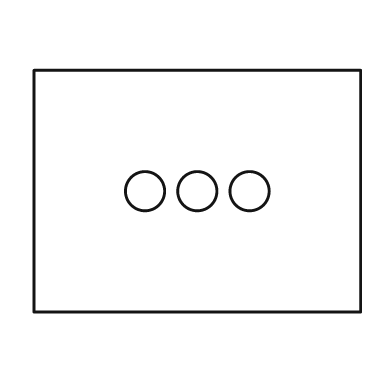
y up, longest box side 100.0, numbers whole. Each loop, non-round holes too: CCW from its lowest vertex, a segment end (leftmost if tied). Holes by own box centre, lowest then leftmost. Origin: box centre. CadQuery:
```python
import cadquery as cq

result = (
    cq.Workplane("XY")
    .moveTo(-50.0, -37.0)
    .lineTo(50.0, -37.0)
    .lineTo(50.0, 37.0)
    .lineTo(-50.0, 37.0)
    .close()
    .moveTo(-16.0, 0.0)
    .circle(6.0)
    .moveTo(0.0, 0.0)
    .circle(6.0)
    .moveTo(16.0, 0.0)
    .circle(6.0)
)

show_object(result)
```